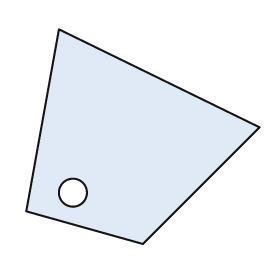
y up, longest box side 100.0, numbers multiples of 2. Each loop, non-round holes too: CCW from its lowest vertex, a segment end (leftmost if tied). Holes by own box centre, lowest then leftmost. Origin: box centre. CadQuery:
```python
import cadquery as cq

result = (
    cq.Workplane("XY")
    .moveTo(0.0, -46.0)
    .lineTo(50.0, 4.0)
    .lineTo(-36.0, 46.0)
    .lineTo(-50.0, -32.0)
    .close()
    .moveTo(-30.0, -24.0)
    .circle(6.0)
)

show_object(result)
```